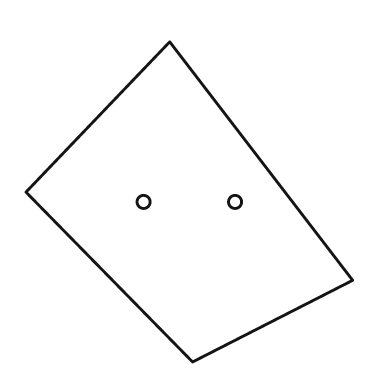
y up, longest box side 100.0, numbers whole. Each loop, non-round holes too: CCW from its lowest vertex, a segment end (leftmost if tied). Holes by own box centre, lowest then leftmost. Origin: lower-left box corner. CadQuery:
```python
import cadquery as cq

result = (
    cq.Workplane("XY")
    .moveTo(51.0, 0.0)
    .lineTo(100.0, 25.0)
    .lineTo(44.0, 98.0)
    .lineTo(0.0, 52.0)
    .close()
    .moveTo(36.0, 49.0)
    .circle(2.0)
    .moveTo(64.0, 49.0)
    .circle(2.0)
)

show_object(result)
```